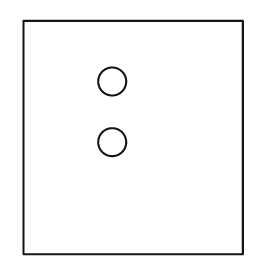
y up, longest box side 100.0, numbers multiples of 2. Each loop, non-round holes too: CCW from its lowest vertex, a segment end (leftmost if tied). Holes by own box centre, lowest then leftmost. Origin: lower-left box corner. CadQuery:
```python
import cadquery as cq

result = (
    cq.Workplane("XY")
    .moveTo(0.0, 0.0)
    .lineTo(94.0, 0.0)
    .lineTo(94.0, 100.0)
    .lineTo(0.0, 100.0)
    .close()
    .moveTo(38.0, 48.0)
    .circle(6.0)
    .moveTo(38.0, 74.0)
    .circle(6.0)
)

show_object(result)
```